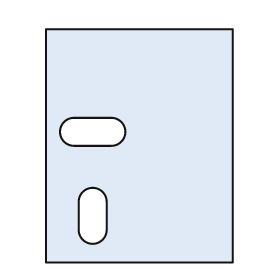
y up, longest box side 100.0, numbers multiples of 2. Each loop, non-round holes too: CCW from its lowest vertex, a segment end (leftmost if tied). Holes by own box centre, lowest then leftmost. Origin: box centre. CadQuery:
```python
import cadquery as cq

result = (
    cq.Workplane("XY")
    .moveTo(-40.0, -50.0)
    .lineTo(40.0, -50.0)
    .lineTo(40.0, 50.0)
    .lineTo(-40.0, 50.0)
    .close()
    .moveTo(-26.0, -36.0)
    .threePointArc((-20.0, -42.0), (-14.0, -36.0))
    .lineTo(-14.0, -24.0)
    .threePointArc((-20.0, -18.0), (-26.0, -24.0))
    .close()
    .moveTo(-28.0, 0.0)
    .lineTo(-12.0, 0.0)
    .threePointArc((-6.0, 6.0), (-12.0, 12.0))
    .lineTo(-28.0, 12.0)
    .threePointArc((-34.0, 6.0), (-28.0, 0.0))
    .close()
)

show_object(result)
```